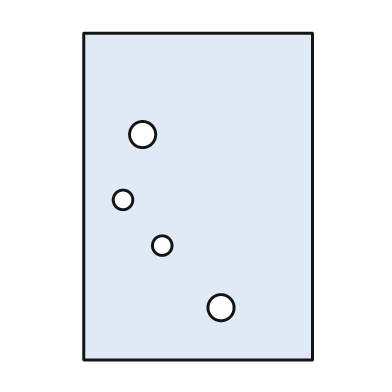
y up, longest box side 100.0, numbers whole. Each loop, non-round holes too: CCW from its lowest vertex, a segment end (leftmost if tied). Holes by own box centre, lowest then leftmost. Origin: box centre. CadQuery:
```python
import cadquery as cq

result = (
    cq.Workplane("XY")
    .moveTo(-35.0, -50.0)
    .lineTo(35.0, -50.0)
    .lineTo(35.0, 50.0)
    .lineTo(-35.0, 50.0)
    .close()
    .moveTo(7.0, -34.0)
    .circle(4.0)
    .moveTo(-11.0, -15.0)
    .circle(3.0)
    .moveTo(-23.0, -1.0)
    .circle(3.0)
    .moveTo(-17.0, 19.0)
    .circle(4.0)
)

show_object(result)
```